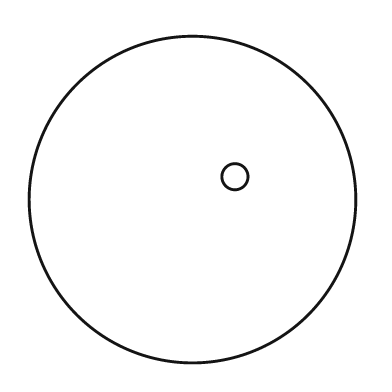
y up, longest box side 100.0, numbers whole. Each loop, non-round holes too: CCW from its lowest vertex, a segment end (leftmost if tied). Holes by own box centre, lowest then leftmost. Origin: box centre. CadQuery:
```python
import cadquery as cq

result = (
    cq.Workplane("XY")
    .moveTo(0.0, 0.0)
    .circle(50.0)
    .moveTo(13.0, 7.0)
    .circle(4.0)
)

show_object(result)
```